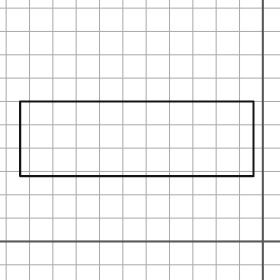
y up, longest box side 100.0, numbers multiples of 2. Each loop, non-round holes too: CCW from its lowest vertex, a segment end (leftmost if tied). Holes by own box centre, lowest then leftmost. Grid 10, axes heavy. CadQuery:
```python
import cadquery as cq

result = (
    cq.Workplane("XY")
    .moveTo(-104.0, 28.0)
    .lineTo(-4.0, 28.0)
    .lineTo(-4.0, 60.0)
    .lineTo(-104.0, 60.0)
    .close()
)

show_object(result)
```